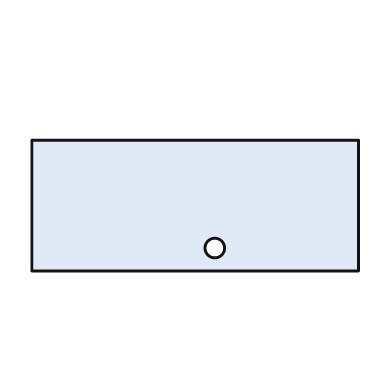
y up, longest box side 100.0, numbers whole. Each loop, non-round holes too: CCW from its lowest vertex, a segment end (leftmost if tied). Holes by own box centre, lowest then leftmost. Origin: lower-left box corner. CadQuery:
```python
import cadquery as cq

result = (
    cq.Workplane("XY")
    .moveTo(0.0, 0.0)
    .lineTo(100.0, 0.0)
    .lineTo(100.0, 40.0)
    .lineTo(0.0, 40.0)
    .close()
    .moveTo(56.0, 7.0)
    .circle(3.0)
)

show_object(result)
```